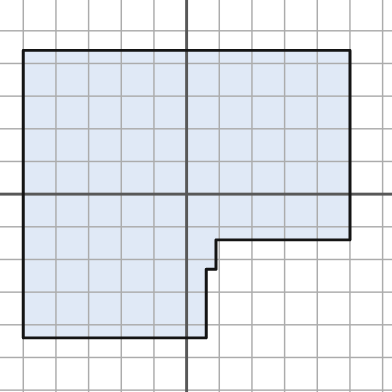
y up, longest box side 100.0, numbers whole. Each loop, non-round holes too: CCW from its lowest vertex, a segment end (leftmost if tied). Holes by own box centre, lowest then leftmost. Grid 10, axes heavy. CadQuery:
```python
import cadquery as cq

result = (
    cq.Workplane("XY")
    .moveTo(-50.0, -44.0)
    .lineTo(6.0, -44.0)
    .lineTo(6.0, -23.0)
    .lineTo(9.0, -23.0)
    .lineTo(9.0, -14.0)
    .lineTo(50.0, -14.0)
    .lineTo(50.0, 44.0)
    .lineTo(-50.0, 44.0)
    .close()
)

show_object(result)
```